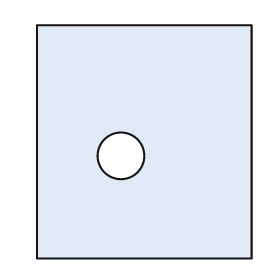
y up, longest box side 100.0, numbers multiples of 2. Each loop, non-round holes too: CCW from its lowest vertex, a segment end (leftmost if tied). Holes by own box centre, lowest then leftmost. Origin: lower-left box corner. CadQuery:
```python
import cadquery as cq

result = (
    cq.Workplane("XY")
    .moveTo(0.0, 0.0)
    .lineTo(92.0, 0.0)
    .lineTo(92.0, 100.0)
    .lineTo(0.0, 100.0)
    .close()
    .moveTo(36.0, 44.0)
    .circle(10.0)
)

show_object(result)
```